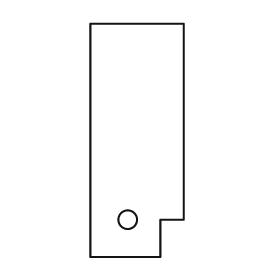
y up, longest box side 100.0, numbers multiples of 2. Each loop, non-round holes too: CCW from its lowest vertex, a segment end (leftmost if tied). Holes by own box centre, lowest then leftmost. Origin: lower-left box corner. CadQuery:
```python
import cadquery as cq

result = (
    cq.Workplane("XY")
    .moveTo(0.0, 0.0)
    .lineTo(30.0, 0.0)
    .lineTo(30.0, 16.0)
    .lineTo(40.0, 16.0)
    .lineTo(40.0, 100.0)
    .lineTo(0.0, 100.0)
    .close()
    .moveTo(16.0, 16.0)
    .circle(4.0)
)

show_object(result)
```